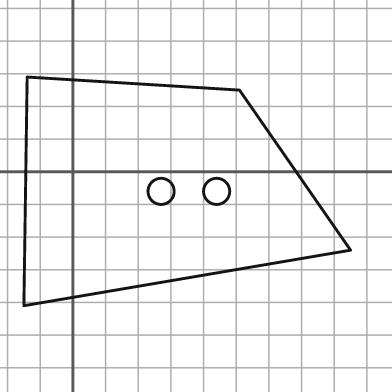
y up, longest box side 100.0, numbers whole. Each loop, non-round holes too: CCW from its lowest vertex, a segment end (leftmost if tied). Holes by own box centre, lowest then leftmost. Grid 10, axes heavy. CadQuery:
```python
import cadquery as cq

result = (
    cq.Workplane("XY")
    .moveTo(-15.0, -41.0)
    .lineTo(85.0, -24.0)
    .lineTo(51.0, 25.0)
    .lineTo(-14.0, 29.0)
    .close()
    .moveTo(27.0, -6.0)
    .circle(4.0)
    .moveTo(44.0, -6.0)
    .circle(4.0)
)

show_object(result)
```